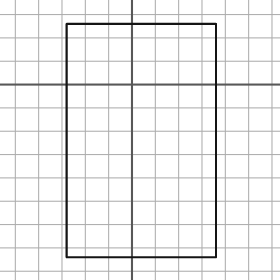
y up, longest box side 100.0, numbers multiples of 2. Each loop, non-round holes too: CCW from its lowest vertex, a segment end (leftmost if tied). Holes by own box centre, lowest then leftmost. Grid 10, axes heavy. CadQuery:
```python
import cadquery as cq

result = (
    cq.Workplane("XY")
    .moveTo(-28.0, -74.0)
    .lineTo(36.0, -74.0)
    .lineTo(36.0, 26.0)
    .lineTo(-28.0, 26.0)
    .close()
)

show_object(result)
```